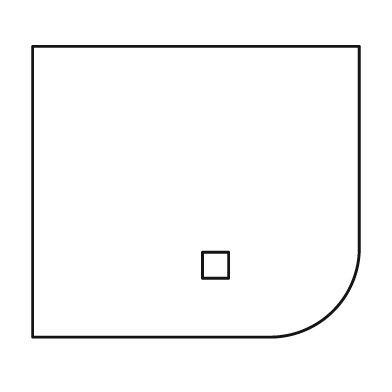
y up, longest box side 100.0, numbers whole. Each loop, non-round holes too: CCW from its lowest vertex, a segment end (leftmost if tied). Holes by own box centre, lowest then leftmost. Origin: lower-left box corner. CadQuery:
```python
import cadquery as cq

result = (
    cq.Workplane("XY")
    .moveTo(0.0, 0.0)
    .lineTo(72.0, 0.0)
    .threePointArc((92.0, 8.0), (100.0, 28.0))
    .lineTo(100.0, 89.0)
    .lineTo(0.0, 89.0)
    .close()
    .moveTo(52.0, 18.0)
    .lineTo(60.0, 18.0)
    .lineTo(60.0, 26.0)
    .lineTo(52.0, 26.0)
    .close()
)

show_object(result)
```